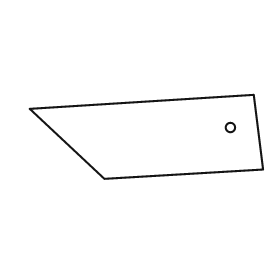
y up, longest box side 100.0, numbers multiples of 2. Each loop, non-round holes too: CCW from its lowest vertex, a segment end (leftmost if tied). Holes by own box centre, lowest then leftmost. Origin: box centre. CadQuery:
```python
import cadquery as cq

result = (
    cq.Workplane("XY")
    .moveTo(-18.0, -18.0)
    .lineTo(50.0, -14.0)
    .lineTo(46.0, 18.0)
    .lineTo(-50.0, 12.0)
    .close()
    .moveTo(36.0, 4.0)
    .circle(2.0)
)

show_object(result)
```